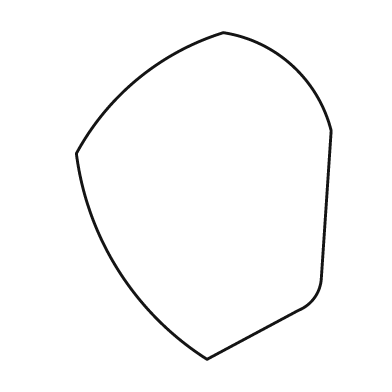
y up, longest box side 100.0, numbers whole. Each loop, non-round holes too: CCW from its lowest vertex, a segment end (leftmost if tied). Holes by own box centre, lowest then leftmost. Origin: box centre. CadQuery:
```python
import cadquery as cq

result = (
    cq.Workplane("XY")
    .moveTo(1.0, -50.0)
    .lineTo(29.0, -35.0)
    .threePointArc((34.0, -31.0), (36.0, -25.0))
    .lineTo(39.0, 20.0)
    .threePointArc((27.0, 40.0), (6.0, 50.0))
    .threePointArc((-20.0, 36.0), (-39.0, 13.0))
    .threePointArc((-26.0, -23.0), (1.0, -50.0))
    .close()
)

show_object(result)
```